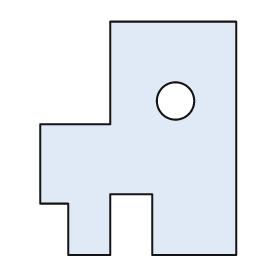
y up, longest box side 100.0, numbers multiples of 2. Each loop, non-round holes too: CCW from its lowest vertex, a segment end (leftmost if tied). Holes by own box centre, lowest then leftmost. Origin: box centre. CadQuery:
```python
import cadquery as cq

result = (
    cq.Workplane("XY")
    .moveTo(-30.0, -50.0)
    .lineTo(-12.0, -50.0)
    .lineTo(-12.0, -24.0)
    .lineTo(6.0, -24.0)
    .lineTo(6.0, -50.0)
    .lineTo(42.0, -50.0)
    .lineTo(42.0, 50.0)
    .lineTo(-12.0, 50.0)
    .lineTo(-12.0, 6.0)
    .lineTo(-42.0, 6.0)
    .lineTo(-42.0, -28.0)
    .lineTo(-30.0, -28.0)
    .close()
    .moveTo(16.0, 16.0)
    .circle(8.0)
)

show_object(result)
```